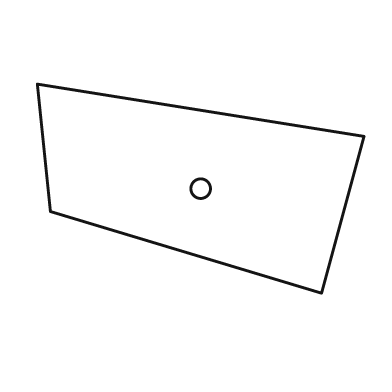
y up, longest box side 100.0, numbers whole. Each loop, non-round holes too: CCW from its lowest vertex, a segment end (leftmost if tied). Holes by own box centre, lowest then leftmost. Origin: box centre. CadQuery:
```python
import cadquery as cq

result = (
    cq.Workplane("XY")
    .moveTo(37.0, -32.0)
    .lineTo(50.0, 16.0)
    .lineTo(-50.0, 32.0)
    .lineTo(-46.0, -7.0)
    .close()
    .moveTo(0.0, 0.0)
    .circle(3.0)
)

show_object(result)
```